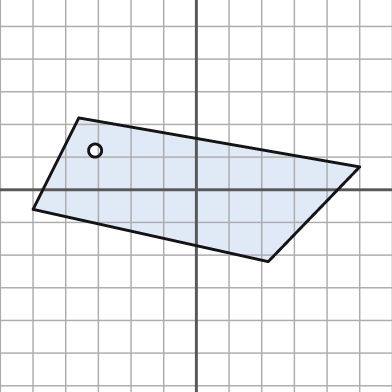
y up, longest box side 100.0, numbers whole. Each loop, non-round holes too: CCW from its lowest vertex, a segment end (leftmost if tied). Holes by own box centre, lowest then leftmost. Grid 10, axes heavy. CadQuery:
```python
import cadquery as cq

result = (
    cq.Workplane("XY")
    .moveTo(22.0, -22.0)
    .lineTo(50.0, 7.0)
    .lineTo(-36.0, 22.0)
    .lineTo(-50.0, -6.0)
    .close()
    .moveTo(-31.0, 12.0)
    .circle(2.0)
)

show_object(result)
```